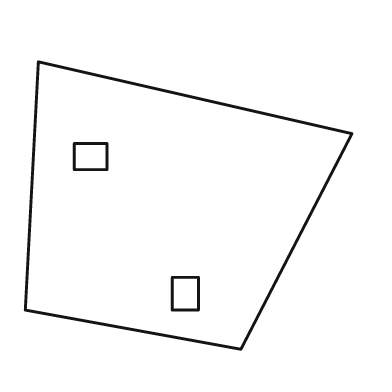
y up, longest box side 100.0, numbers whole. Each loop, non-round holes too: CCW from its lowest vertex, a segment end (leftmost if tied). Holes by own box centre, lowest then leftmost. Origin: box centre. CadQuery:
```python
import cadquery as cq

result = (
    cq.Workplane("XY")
    .moveTo(16.0, -44.0)
    .lineTo(50.0, 22.0)
    .lineTo(-46.0, 44.0)
    .lineTo(-50.0, -32.0)
    .close()
    .moveTo(-5.0, -32.0)
    .lineTo(3.0, -32.0)
    .lineTo(3.0, -22.0)
    .lineTo(-5.0, -22.0)
    .close()
    .moveTo(-35.0, 11.0)
    .lineTo(-25.0, 11.0)
    .lineTo(-25.0, 19.0)
    .lineTo(-35.0, 19.0)
    .close()
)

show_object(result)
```